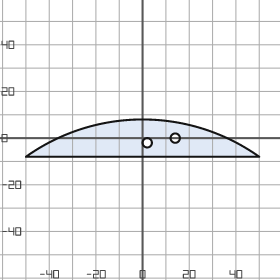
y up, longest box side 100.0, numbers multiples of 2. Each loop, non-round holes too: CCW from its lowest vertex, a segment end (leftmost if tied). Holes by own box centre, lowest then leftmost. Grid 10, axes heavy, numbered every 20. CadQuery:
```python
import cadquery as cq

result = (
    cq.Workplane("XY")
    .moveTo(-50.0, -8.0)
    .lineTo(50.0, -8.0)
    .threePointArc((0.0, 8.0), (-50.0, -8.0))
    .close()
    .moveTo(2.0, -2.0)
    .circle(2.0)
    .moveTo(14.0, 0.0)
    .circle(2.0)
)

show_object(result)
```